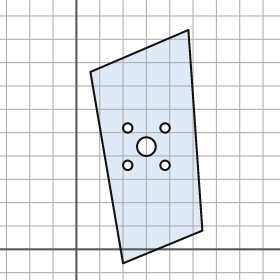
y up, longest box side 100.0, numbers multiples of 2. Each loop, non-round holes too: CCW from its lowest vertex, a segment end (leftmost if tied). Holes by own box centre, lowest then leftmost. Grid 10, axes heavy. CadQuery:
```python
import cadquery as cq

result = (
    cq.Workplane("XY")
    .moveTo(20.0, -6.0)
    .lineTo(54.0, 8.0)
    .lineTo(48.0, 94.0)
    .lineTo(6.0, 76.0)
    .close()
    .moveTo(22.0, 36.0)
    .circle(2.0)
    .moveTo(38.0, 36.0)
    .circle(2.0)
    .moveTo(30.0, 44.0)
    .circle(4.0)
    .moveTo(22.0, 52.0)
    .circle(2.0)
    .moveTo(38.0, 52.0)
    .circle(2.0)
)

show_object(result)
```